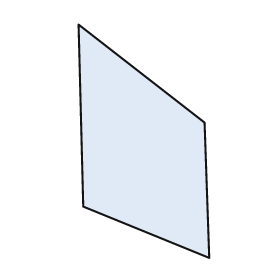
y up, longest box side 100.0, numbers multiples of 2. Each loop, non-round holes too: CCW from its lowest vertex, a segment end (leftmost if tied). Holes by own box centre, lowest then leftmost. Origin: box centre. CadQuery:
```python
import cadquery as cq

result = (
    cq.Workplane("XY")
    .moveTo(28.0, -50.0)
    .lineTo(26.0, 8.0)
    .lineTo(-28.0, 50.0)
    .lineTo(-26.0, -28.0)
    .close()
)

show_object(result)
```